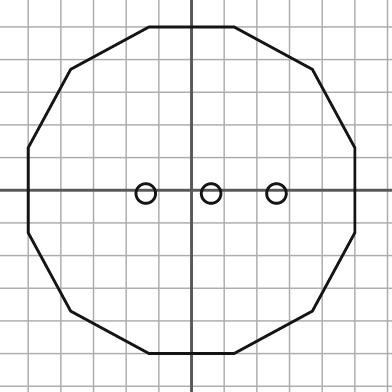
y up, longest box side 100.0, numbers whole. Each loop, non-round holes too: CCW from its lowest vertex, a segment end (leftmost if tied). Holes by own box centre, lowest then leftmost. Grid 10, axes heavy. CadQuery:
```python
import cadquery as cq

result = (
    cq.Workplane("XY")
    .moveTo(-13.0, -50.0)
    .lineTo(13.0, -50.0)
    .lineTo(37.0, -37.0)
    .lineTo(50.0, -13.0)
    .lineTo(50.0, 13.0)
    .lineTo(37.0, 37.0)
    .lineTo(13.0, 50.0)
    .lineTo(-13.0, 50.0)
    .lineTo(-37.0, 37.0)
    .lineTo(-50.0, 13.0)
    .lineTo(-50.0, -13.0)
    .lineTo(-37.0, -37.0)
    .close()
    .moveTo(-14.0, -1.0)
    .circle(3.0)
    .moveTo(6.0, -1.0)
    .circle(3.0)
    .moveTo(26.0, -1.0)
    .circle(3.0)
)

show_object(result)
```